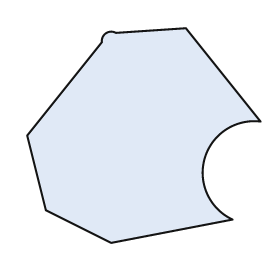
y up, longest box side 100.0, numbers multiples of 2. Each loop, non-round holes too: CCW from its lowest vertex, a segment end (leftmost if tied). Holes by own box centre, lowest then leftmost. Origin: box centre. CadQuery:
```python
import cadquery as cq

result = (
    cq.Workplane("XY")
    .moveTo(-14.0, -46.0)
    .lineTo(38.0, -36.0)
    .threePointArc((26.0, -10.0), (50.0, 6.0))
    .lineTo(18.0, 46.0)
    .lineTo(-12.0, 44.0)
    .threePointArc((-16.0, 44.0), (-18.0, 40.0))
    .lineTo(-50.0, 0.0)
    .lineTo(-42.0, -32.0)
    .close()
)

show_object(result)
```